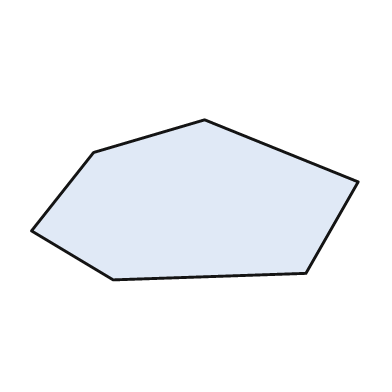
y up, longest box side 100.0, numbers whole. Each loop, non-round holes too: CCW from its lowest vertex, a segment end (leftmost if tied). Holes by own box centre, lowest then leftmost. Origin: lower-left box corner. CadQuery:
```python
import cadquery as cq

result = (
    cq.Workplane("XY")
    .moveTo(25.0, 0.0)
    .lineTo(84.0, 2.0)
    .lineTo(100.0, 30.0)
    .lineTo(53.0, 49.0)
    .lineTo(19.0, 39.0)
    .lineTo(0.0, 15.0)
    .close()
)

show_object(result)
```